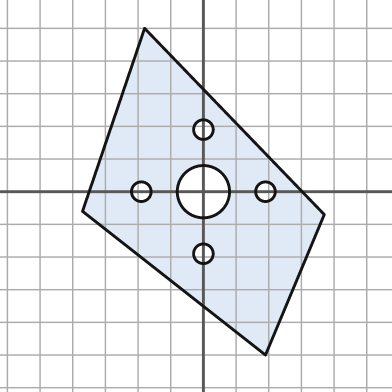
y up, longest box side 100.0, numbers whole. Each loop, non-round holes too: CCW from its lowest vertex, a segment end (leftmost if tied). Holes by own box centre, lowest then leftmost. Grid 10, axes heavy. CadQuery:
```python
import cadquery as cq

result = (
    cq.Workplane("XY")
    .moveTo(19.0, -50.0)
    .lineTo(37.0, -7.0)
    .lineTo(-18.0, 50.0)
    .lineTo(-37.0, -6.0)
    .close()
    .moveTo(0.0, -19.0)
    .circle(3.0)
    .moveTo(-19.0, 0.0)
    .circle(3.0)
    .moveTo(0.0, 0.0)
    .circle(8.0)
    .moveTo(19.0, 0.0)
    .circle(3.0)
    .moveTo(0.0, 19.0)
    .circle(3.0)
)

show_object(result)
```